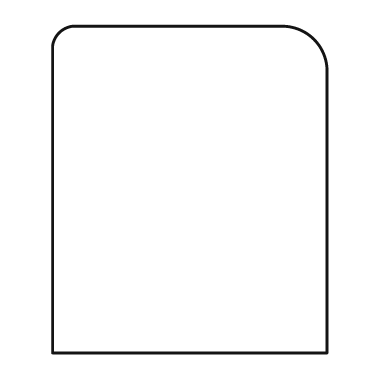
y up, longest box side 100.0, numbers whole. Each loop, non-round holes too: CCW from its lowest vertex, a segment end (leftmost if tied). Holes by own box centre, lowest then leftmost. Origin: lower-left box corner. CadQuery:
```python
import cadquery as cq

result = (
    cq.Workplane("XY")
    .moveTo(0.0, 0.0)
    .lineTo(84.0, 0.0)
    .lineTo(84.0, 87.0)
    .threePointArc((80.0, 96.0), (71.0, 100.0))
    .lineTo(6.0, 100.0)
    .threePointArc((2.0, 98.0), (0.0, 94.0))
    .close()
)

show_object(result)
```